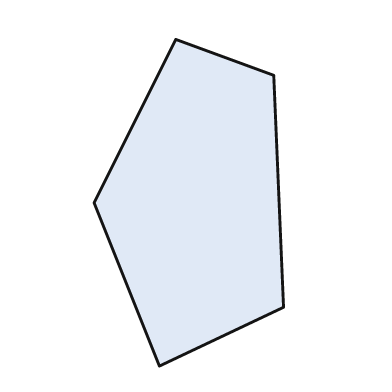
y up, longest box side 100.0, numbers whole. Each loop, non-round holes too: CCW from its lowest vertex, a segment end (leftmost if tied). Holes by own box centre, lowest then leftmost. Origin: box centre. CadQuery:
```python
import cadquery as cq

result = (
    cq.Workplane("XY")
    .moveTo(-9.0, -50.0)
    .lineTo(29.0, -32.0)
    .lineTo(26.0, 39.0)
    .lineTo(-4.0, 50.0)
    .lineTo(-29.0, 0.0)
    .close()
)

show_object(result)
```